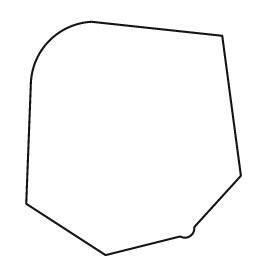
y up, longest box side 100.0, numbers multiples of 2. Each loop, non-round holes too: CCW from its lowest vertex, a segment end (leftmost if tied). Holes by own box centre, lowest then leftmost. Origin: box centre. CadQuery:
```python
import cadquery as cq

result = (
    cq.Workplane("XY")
    .moveTo(-12.0, -50.0)
    .lineTo(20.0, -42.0)
    .threePointArc((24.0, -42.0), (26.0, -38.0))
    .lineTo(46.0, -16.0)
    .lineTo(38.0, 44.0)
    .lineTo(-18.0, 50.0)
    .threePointArc((-36.0, 42.0), (-44.0, 24.0))
    .lineTo(-46.0, -28.0)
    .close()
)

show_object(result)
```